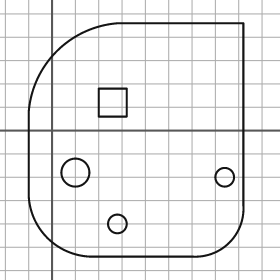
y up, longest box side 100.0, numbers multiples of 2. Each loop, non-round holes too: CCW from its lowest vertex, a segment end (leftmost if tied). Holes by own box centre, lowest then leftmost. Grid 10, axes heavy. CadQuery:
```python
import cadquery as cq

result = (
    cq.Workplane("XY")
    .moveTo(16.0, -54.0)
    .lineTo(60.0, -54.0)
    .threePointArc((76.0, -48.0), (82.0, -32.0))
    .lineTo(82.0, 46.0)
    .lineTo(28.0, 46.0)
    .threePointArc((2.0, 34.0), (-10.0, 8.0))
    .lineTo(-10.0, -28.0)
    .threePointArc((-2.0, -46.0), (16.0, -54.0))
    .close()
    .moveTo(28.0, -40.0)
    .circle(4.0)
    .moveTo(74.0, -20.0)
    .circle(4.0)
    .moveTo(10.0, -18.0)
    .circle(6.0)
    .moveTo(20.0, 6.0)
    .lineTo(32.0, 6.0)
    .lineTo(32.0, 18.0)
    .lineTo(20.0, 18.0)
    .close()
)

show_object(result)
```